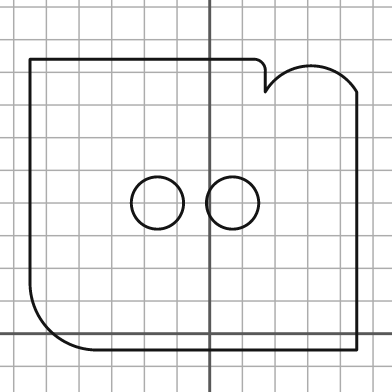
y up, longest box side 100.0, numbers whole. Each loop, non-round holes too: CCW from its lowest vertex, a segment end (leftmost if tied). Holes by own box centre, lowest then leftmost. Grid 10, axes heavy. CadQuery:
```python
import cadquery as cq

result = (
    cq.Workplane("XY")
    .moveTo(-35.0, -5.0)
    .lineTo(45.0, -5.0)
    .lineTo(45.0, 74.0)
    .threePointArc((31.0, 82.0), (17.0, 74.0))
    .lineTo(17.0, 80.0)
    .threePointArc((16.0, 83.0), (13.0, 84.0))
    .lineTo(-55.0, 84.0)
    .lineTo(-55.0, 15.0)
    .threePointArc((-49.0, 1.0), (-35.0, -5.0))
    .close()
    .moveTo(-16.0, 40.0)
    .circle(8.0)
    .moveTo(7.0, 40.0)
    .circle(8.0)
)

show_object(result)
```